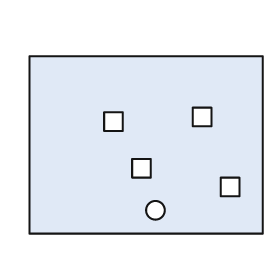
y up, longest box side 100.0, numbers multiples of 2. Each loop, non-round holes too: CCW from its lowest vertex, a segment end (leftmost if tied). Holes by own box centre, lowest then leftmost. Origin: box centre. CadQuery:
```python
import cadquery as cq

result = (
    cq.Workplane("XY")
    .moveTo(-50.0, -38.0)
    .lineTo(50.0, -38.0)
    .lineTo(50.0, 38.0)
    .lineTo(-50.0, 38.0)
    .close()
    .moveTo(4.0, -28.0)
    .circle(4.0)
    .moveTo(32.0, -22.0)
    .lineTo(40.0, -22.0)
    .lineTo(40.0, -14.0)
    .lineTo(32.0, -14.0)
    .close()
    .moveTo(-6.0, -14.0)
    .lineTo(2.0, -14.0)
    .lineTo(2.0, -6.0)
    .lineTo(-6.0, -6.0)
    .close()
    .moveTo(-18.0, 6.0)
    .lineTo(-10.0, 6.0)
    .lineTo(-10.0, 14.0)
    .lineTo(-18.0, 14.0)
    .close()
    .moveTo(20.0, 8.0)
    .lineTo(28.0, 8.0)
    .lineTo(28.0, 16.0)
    .lineTo(20.0, 16.0)
    .close()
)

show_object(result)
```